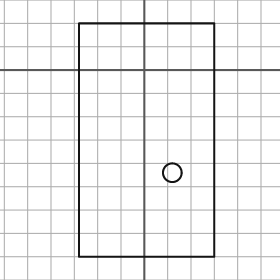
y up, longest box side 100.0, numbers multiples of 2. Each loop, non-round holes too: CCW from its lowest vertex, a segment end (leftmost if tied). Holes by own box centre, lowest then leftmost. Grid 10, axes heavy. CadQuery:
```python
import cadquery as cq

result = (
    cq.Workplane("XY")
    .moveTo(-28.0, -80.0)
    .lineTo(30.0, -80.0)
    .lineTo(30.0, 20.0)
    .lineTo(-28.0, 20.0)
    .close()
    .moveTo(12.0, -44.0)
    .circle(4.0)
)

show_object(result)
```